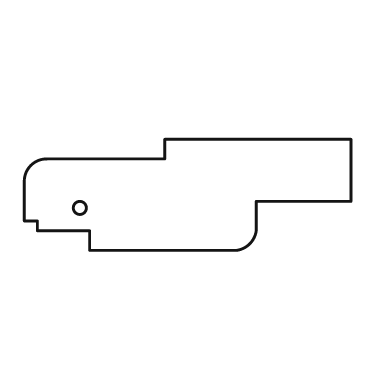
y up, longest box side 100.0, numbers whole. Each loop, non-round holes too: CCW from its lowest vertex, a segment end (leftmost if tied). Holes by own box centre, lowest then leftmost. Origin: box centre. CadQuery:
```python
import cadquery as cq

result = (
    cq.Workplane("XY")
    .moveTo(-30.0, -17.0)
    .lineTo(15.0, -17.0)
    .threePointArc((19.0, -15.0), (21.0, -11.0))
    .lineTo(21.0, -2.0)
    .lineTo(50.0, -2.0)
    .lineTo(50.0, 17.0)
    .lineTo(-7.0, 17.0)
    .lineTo(-7.0, 11.0)
    .lineTo(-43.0, 11.0)
    .threePointArc((-48.0, 9.0), (-50.0, 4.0))
    .lineTo(-50.0, -8.0)
    .lineTo(-46.0, -8.0)
    .lineTo(-46.0, -11.0)
    .lineTo(-30.0, -11.0)
    .close()
    .moveTo(-33.0, -4.0)
    .circle(2.0)
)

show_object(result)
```